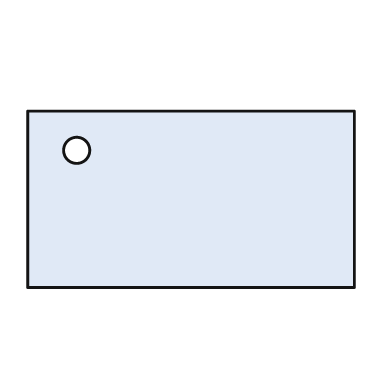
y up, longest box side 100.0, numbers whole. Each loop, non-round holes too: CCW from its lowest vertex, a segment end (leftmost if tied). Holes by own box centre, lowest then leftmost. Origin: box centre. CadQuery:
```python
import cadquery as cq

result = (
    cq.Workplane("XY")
    .moveTo(-50.0, -27.0)
    .lineTo(50.0, -27.0)
    .lineTo(50.0, 27.0)
    .lineTo(-50.0, 27.0)
    .close()
    .moveTo(-35.0, 15.0)
    .circle(4.0)
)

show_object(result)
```